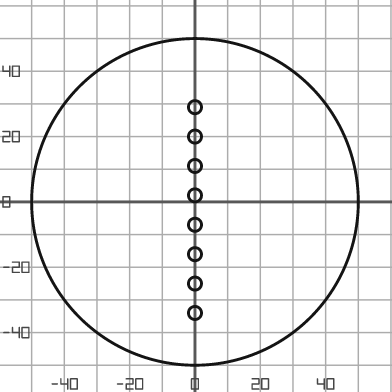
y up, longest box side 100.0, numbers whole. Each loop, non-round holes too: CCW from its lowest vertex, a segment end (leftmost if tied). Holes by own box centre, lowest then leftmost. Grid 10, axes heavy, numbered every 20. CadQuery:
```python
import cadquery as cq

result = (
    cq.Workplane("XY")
    .moveTo(0.0, 0.0)
    .circle(50.0)
    .moveTo(0.0, -34.0)
    .circle(2.0)
    .moveTo(0.0, -25.0)
    .circle(2.0)
    .moveTo(0.0, -16.0)
    .circle(2.0)
    .moveTo(0.0, -7.0)
    .circle(2.0)
    .moveTo(0.0, 2.0)
    .circle(2.0)
    .moveTo(0.0, 11.0)
    .circle(2.0)
    .moveTo(0.0, 20.0)
    .circle(2.0)
    .moveTo(0.0, 29.0)
    .circle(2.0)
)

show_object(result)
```